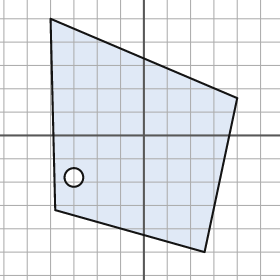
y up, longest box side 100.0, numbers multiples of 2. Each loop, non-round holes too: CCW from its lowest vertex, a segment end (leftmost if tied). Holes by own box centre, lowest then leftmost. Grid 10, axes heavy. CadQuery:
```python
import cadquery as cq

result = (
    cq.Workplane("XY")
    .moveTo(26.0, -50.0)
    .lineTo(40.0, 16.0)
    .lineTo(-40.0, 50.0)
    .lineTo(-38.0, -32.0)
    .close()
    .moveTo(-30.0, -18.0)
    .circle(4.0)
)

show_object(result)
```